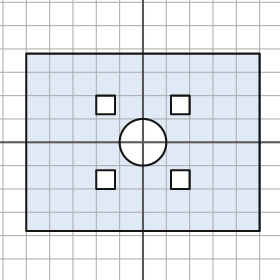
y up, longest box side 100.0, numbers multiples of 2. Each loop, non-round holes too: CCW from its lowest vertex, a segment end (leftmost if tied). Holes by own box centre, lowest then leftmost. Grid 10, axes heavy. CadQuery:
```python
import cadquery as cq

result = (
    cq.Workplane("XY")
    .moveTo(-50.0, -38.0)
    .lineTo(50.0, -38.0)
    .lineTo(50.0, 38.0)
    .lineTo(-50.0, 38.0)
    .close()
    .moveTo(-20.0, -20.0)
    .lineTo(-12.0, -20.0)
    .lineTo(-12.0, -12.0)
    .lineTo(-20.0, -12.0)
    .close()
    .moveTo(12.0, -20.0)
    .lineTo(20.0, -20.0)
    .lineTo(20.0, -12.0)
    .lineTo(12.0, -12.0)
    .close()
    .moveTo(0.0, 0.0)
    .circle(10.0)
    .moveTo(-20.0, 12.0)
    .lineTo(-12.0, 12.0)
    .lineTo(-12.0, 20.0)
    .lineTo(-20.0, 20.0)
    .close()
    .moveTo(12.0, 12.0)
    .lineTo(20.0, 12.0)
    .lineTo(20.0, 20.0)
    .lineTo(12.0, 20.0)
    .close()
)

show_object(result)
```